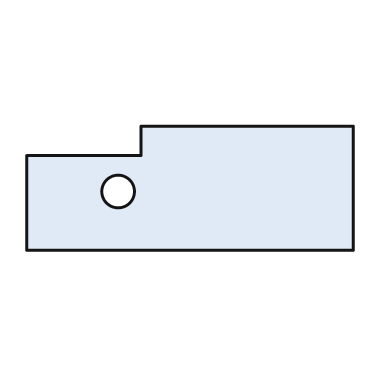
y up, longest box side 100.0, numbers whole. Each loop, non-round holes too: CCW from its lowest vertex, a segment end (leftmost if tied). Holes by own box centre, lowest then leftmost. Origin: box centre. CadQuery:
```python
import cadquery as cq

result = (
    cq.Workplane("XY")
    .moveTo(-50.0, -19.0)
    .lineTo(50.0, -19.0)
    .lineTo(50.0, 19.0)
    .lineTo(-15.0, 19.0)
    .lineTo(-15.0, 10.0)
    .lineTo(-50.0, 10.0)
    .close()
    .moveTo(-22.0, -1.0)
    .circle(5.0)
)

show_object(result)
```